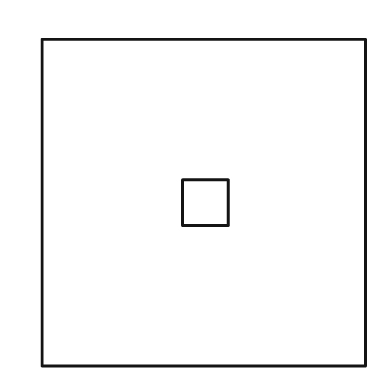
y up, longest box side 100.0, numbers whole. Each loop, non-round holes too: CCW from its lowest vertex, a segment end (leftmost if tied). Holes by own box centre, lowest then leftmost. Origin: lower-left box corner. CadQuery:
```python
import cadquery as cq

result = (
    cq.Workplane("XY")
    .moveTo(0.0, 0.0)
    .lineTo(99.0, 0.0)
    .lineTo(99.0, 100.0)
    .lineTo(0.0, 100.0)
    .close()
    .moveTo(43.0, 43.0)
    .lineTo(57.0, 43.0)
    .lineTo(57.0, 57.0)
    .lineTo(43.0, 57.0)
    .close()
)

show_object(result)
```